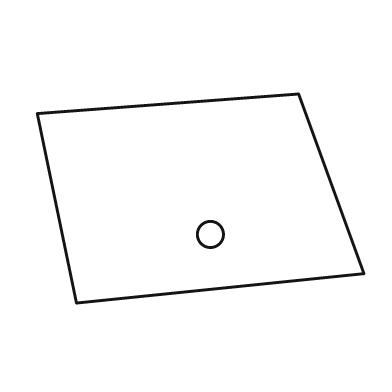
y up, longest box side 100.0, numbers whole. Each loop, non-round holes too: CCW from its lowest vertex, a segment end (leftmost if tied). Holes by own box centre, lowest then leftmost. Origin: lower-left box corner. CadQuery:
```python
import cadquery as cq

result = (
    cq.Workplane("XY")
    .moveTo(12.0, 0.0)
    .lineTo(100.0, 9.0)
    .lineTo(80.0, 64.0)
    .lineTo(0.0, 58.0)
    .close()
    .moveTo(53.0, 21.0)
    .circle(4.0)
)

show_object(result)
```